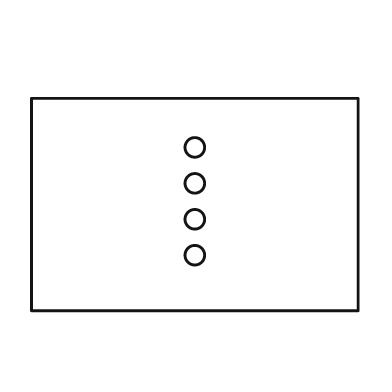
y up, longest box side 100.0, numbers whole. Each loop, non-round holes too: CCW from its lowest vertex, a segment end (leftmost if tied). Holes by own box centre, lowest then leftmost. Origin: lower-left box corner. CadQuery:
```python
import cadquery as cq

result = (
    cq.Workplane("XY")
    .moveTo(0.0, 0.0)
    .lineTo(100.0, 0.0)
    .lineTo(100.0, 65.0)
    .lineTo(0.0, 65.0)
    .close()
    .moveTo(50.0, 17.0)
    .circle(3.0)
    .moveTo(50.0, 28.0)
    .circle(3.0)
    .moveTo(50.0, 39.0)
    .circle(3.0)
    .moveTo(50.0, 50.0)
    .circle(3.0)
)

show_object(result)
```